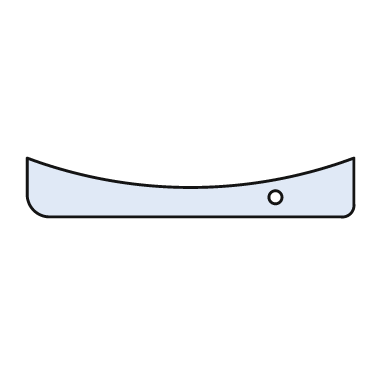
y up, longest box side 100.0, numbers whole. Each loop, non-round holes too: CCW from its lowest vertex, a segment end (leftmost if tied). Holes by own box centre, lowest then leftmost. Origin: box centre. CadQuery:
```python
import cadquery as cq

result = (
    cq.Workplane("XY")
    .moveTo(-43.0, -9.0)
    .lineTo(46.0, -9.0)
    .threePointArc((49.0, -8.0), (50.0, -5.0))
    .lineTo(50.0, 9.0)
    .threePointArc((0.0, 0.0), (-50.0, 9.0))
    .lineTo(-50.0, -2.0)
    .threePointArc((-48.0, -7.0), (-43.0, -9.0))
    .close()
    .moveTo(26.0, -3.0)
    .circle(2.0)
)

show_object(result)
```